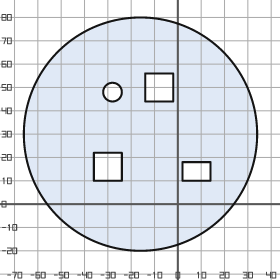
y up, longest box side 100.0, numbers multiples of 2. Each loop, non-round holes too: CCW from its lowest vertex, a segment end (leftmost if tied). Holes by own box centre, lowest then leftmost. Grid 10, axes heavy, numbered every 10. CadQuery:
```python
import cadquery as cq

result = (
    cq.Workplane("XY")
    .moveTo(-16.0, 30.0)
    .circle(50.0)
    .moveTo(2.0, 10.0)
    .lineTo(14.0, 10.0)
    .lineTo(14.0, 18.0)
    .lineTo(2.0, 18.0)
    .close()
    .moveTo(-36.0, 10.0)
    .lineTo(-24.0, 10.0)
    .lineTo(-24.0, 22.0)
    .lineTo(-36.0, 22.0)
    .close()
    .moveTo(-28.0, 48.0)
    .circle(4.0)
    .moveTo(-14.0, 44.0)
    .lineTo(-2.0, 44.0)
    .lineTo(-2.0, 56.0)
    .lineTo(-14.0, 56.0)
    .close()
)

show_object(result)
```